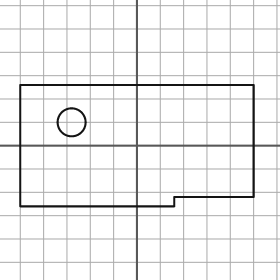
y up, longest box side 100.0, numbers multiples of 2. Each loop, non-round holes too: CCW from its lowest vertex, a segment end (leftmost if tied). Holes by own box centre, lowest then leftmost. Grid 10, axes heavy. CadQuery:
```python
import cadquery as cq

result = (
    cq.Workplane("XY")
    .moveTo(-50.0, -26.0)
    .lineTo(16.0, -26.0)
    .lineTo(16.0, -22.0)
    .lineTo(50.0, -22.0)
    .lineTo(50.0, 26.0)
    .lineTo(-50.0, 26.0)
    .close()
    .moveTo(-28.0, 10.0)
    .circle(6.0)
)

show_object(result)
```